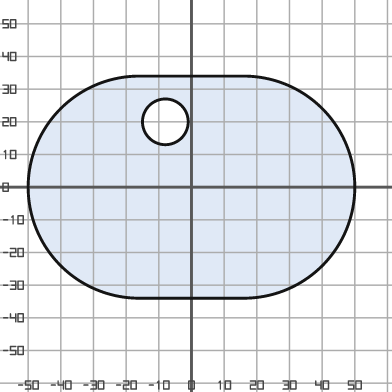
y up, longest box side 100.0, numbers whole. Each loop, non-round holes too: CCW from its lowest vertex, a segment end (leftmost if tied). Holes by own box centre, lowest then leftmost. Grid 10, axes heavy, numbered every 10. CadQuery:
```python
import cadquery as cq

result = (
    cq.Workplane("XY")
    .moveTo(-16.0, -34.0)
    .lineTo(16.0, -34.0)
    .threePointArc((50.0, 0.0), (16.0, 34.0))
    .lineTo(-16.0, 34.0)
    .threePointArc((-50.0, 0.0), (-16.0, -34.0))
    .close()
    .moveTo(-8.0, 20.0)
    .circle(7.0)
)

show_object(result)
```